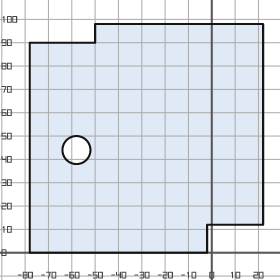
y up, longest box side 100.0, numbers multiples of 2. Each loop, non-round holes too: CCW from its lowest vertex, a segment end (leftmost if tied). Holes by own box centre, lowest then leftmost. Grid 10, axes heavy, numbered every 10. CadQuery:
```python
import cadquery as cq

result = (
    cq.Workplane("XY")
    .moveTo(-78.0, 0.0)
    .lineTo(-2.0, 0.0)
    .lineTo(-2.0, 12.0)
    .lineTo(22.0, 12.0)
    .lineTo(22.0, 98.0)
    .lineTo(-50.0, 98.0)
    .lineTo(-50.0, 90.0)
    .lineTo(-78.0, 90.0)
    .close()
    .moveTo(-58.0, 44.0)
    .circle(6.0)
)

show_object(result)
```